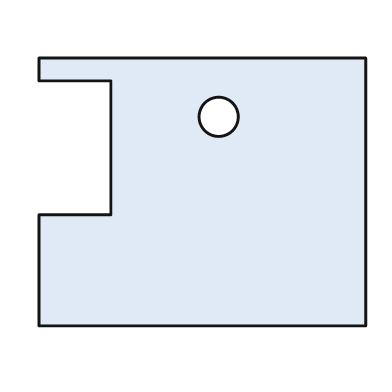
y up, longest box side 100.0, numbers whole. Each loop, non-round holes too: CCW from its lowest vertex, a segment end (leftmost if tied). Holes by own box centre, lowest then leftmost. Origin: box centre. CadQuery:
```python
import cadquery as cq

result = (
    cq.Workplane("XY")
    .moveTo(-50.0, -41.0)
    .lineTo(50.0, -41.0)
    .lineTo(50.0, 41.0)
    .lineTo(-50.0, 41.0)
    .lineTo(-50.0, 34.0)
    .lineTo(-28.0, 34.0)
    .lineTo(-28.0, -7.0)
    .lineTo(-50.0, -7.0)
    .close()
    .moveTo(5.0, 23.0)
    .circle(6.0)
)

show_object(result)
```